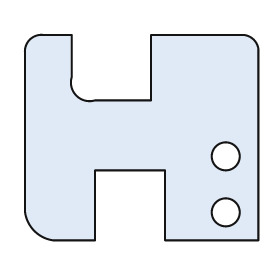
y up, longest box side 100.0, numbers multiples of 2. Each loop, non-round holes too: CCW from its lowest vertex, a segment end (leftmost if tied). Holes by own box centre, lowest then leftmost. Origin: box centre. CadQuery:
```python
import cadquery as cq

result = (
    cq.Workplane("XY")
    .moveTo(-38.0, -44.0)
    .lineTo(-20.0, -44.0)
    .lineTo(-20.0, -14.0)
    .lineTo(10.0, -14.0)
    .lineTo(10.0, -44.0)
    .lineTo(50.0, -44.0)
    .lineTo(50.0, 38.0)
    .threePointArc((48.0, 42.0), (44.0, 44.0))
    .lineTo(4.0, 44.0)
    .lineTo(4.0, 16.0)
    .lineTo(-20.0, 16.0)
    .threePointArc((-28.0, 18.0), (-30.0, 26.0))
    .lineTo(-30.0, 44.0)
    .lineTo(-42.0, 44.0)
    .threePointArc((-48.0, 42.0), (-50.0, 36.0))
    .lineTo(-50.0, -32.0)
    .threePointArc((-46.0, -40.0), (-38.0, -44.0))
    .close()
    .moveTo(36.0, -32.0)
    .circle(6.0)
    .moveTo(36.0, -8.0)
    .circle(6.0)
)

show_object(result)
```